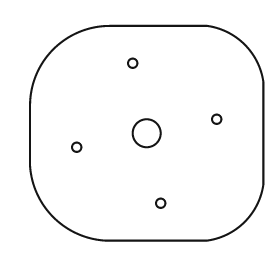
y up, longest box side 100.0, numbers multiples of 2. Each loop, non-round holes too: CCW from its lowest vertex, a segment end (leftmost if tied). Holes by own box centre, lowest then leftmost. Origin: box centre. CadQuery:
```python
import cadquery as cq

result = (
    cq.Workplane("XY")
    .moveTo(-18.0, -46.0)
    .lineTo(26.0, -46.0)
    .threePointArc((42.0, -38.0), (50.0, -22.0))
    .lineTo(50.0, 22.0)
    .threePointArc((42.0, 38.0), (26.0, 46.0))
    .lineTo(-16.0, 46.0)
    .threePointArc((-40.0, 36.0), (-50.0, 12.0))
    .lineTo(-50.0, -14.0)
    .threePointArc((-40.0, -36.0), (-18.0, -46.0))
    .close()
    .moveTo(6.0, -30.0)
    .circle(2.0)
    .moveTo(-30.0, -6.0)
    .circle(2.0)
    .moveTo(0.0, 0.0)
    .circle(6.0)
    .moveTo(30.0, 6.0)
    .circle(2.0)
    .moveTo(-6.0, 30.0)
    .circle(2.0)
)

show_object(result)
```